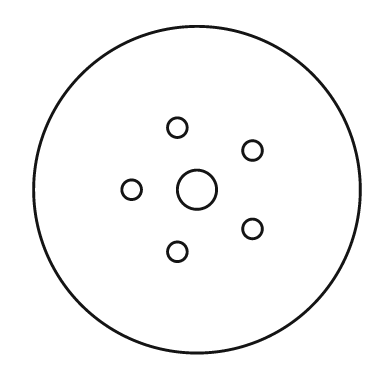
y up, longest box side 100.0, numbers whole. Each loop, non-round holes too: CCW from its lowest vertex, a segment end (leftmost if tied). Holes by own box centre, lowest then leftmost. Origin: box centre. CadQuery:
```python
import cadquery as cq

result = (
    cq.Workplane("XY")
    .moveTo(0.0, 0.0)
    .circle(50.0)
    .moveTo(-6.0, -19.0)
    .circle(3.0)
    .moveTo(17.0, -12.0)
    .circle(3.0)
    .moveTo(-20.0, 0.0)
    .circle(3.0)
    .moveTo(0.0, 0.0)
    .circle(6.0)
    .moveTo(17.0, 12.0)
    .circle(3.0)
    .moveTo(-6.0, 19.0)
    .circle(3.0)
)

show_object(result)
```